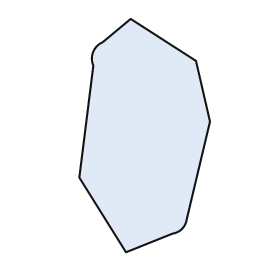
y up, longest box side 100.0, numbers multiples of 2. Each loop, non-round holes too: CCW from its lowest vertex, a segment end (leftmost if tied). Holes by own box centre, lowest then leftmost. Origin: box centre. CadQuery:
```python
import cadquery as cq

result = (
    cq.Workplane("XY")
    .moveTo(-8.0, -50.0)
    .lineTo(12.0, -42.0)
    .threePointArc((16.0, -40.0), (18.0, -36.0))
    .lineTo(28.0, 6.0)
    .lineTo(22.0, 32.0)
    .lineTo(-6.0, 50.0)
    .lineTo(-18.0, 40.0)
    .threePointArc((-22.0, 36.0), (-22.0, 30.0))
    .lineTo(-28.0, -18.0)
    .close()
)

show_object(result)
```